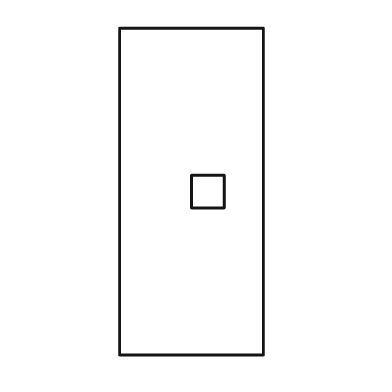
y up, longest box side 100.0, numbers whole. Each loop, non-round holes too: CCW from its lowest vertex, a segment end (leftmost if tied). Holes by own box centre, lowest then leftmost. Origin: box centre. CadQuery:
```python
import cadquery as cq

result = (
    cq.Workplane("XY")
    .moveTo(-22.0, -50.0)
    .lineTo(22.0, -50.0)
    .lineTo(22.0, 50.0)
    .lineTo(-22.0, 50.0)
    .close()
    .moveTo(0.0, -5.0)
    .lineTo(10.0, -5.0)
    .lineTo(10.0, 5.0)
    .lineTo(0.0, 5.0)
    .close()
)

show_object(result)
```